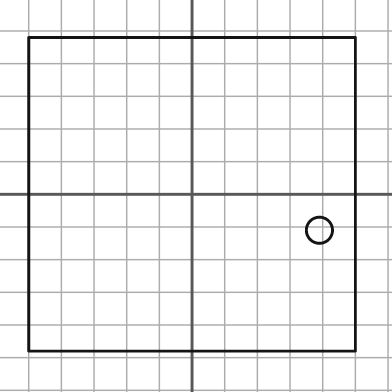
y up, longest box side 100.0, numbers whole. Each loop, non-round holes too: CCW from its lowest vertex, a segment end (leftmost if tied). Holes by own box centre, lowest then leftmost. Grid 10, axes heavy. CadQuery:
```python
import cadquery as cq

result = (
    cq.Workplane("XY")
    .moveTo(-50.0, -48.0)
    .lineTo(50.0, -48.0)
    .lineTo(50.0, 48.0)
    .lineTo(-50.0, 48.0)
    .close()
    .moveTo(39.0, -11.0)
    .circle(4.0)
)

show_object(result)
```